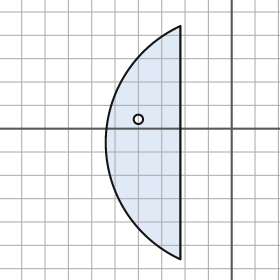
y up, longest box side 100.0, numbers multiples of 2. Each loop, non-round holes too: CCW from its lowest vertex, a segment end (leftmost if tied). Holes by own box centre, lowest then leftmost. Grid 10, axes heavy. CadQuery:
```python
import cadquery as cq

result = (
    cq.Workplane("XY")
    .moveTo(-22.0, -56.0)
    .lineTo(-22.0, 44.0)
    .threePointArc((-54.0, -6.0), (-22.0, -56.0))
    .close()
    .moveTo(-40.0, 4.0)
    .circle(2.0)
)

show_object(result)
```